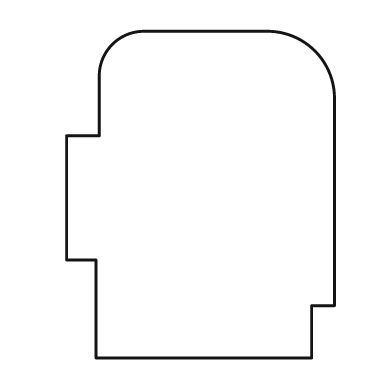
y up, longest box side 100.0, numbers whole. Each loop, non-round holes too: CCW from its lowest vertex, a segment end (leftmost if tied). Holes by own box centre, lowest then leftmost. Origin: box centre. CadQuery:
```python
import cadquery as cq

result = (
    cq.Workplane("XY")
    .moveTo(-32.0, -50.0)
    .lineTo(34.0, -50.0)
    .lineTo(34.0, -34.0)
    .lineTo(41.0, -34.0)
    .lineTo(41.0, 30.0)
    .threePointArc((35.0, 44.0), (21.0, 50.0))
    .lineTo(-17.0, 50.0)
    .threePointArc((-27.0, 46.0), (-31.0, 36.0))
    .lineTo(-31.0, 18.0)
    .lineTo(-41.0, 18.0)
    .lineTo(-41.0, -20.0)
    .lineTo(-32.0, -20.0)
    .close()
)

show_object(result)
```